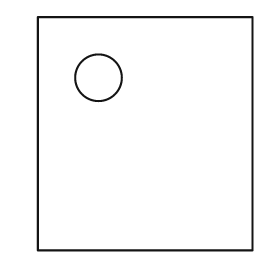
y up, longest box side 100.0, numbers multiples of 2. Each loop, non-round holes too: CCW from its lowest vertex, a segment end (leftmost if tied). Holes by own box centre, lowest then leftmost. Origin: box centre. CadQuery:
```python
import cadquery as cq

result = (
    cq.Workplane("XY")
    .moveTo(-46.0, -50.0)
    .lineTo(46.0, -50.0)
    .lineTo(46.0, 50.0)
    .lineTo(-46.0, 50.0)
    .close()
    .moveTo(-20.0, 24.0)
    .circle(10.0)
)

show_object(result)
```